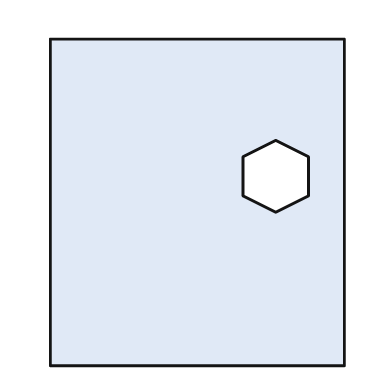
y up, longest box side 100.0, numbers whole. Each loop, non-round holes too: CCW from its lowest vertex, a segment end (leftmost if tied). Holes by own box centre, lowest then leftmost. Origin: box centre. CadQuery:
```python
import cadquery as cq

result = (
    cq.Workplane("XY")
    .moveTo(-45.0, -50.0)
    .lineTo(45.0, -50.0)
    .lineTo(45.0, 50.0)
    .lineTo(-45.0, 50.0)
    .close()
    .moveTo(24.0, -3.0)
    .lineTo(34.0, 2.0)
    .lineTo(34.0, 14.0)
    .lineTo(24.0, 19.0)
    .lineTo(14.0, 14.0)
    .lineTo(14.0, 2.0)
    .close()
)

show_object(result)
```